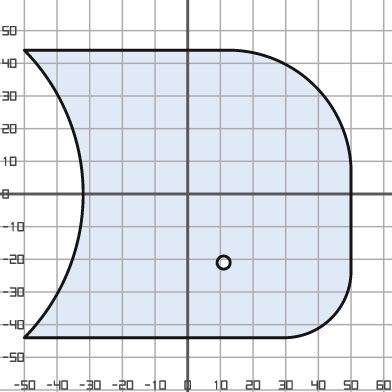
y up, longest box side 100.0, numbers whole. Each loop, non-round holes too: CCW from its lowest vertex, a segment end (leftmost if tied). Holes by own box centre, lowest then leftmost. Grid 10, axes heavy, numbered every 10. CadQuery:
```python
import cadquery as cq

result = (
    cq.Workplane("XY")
    .moveTo(-50.0, -44.0)
    .lineTo(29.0, -44.0)
    .threePointArc((44.0, -38.0), (50.0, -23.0))
    .lineTo(50.0, 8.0)
    .threePointArc((39.0, 33.0), (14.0, 44.0))
    .lineTo(-50.0, 44.0)
    .threePointArc((-32.0, 0.0), (-50.0, -44.0))
    .close()
    .moveTo(11.0, -21.0)
    .circle(2.0)
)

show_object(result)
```